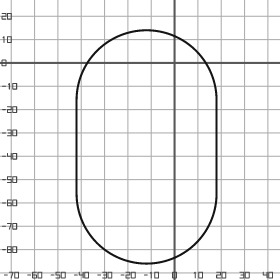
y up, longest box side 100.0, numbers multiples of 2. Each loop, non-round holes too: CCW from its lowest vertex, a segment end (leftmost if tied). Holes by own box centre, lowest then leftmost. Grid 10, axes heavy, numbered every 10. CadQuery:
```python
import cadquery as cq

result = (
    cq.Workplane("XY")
    .moveTo(-42.0, -56.0)
    .threePointArc((-12.0, -86.0), (18.0, -56.0))
    .lineTo(18.0, -16.0)
    .threePointArc((-12.0, 14.0), (-42.0, -16.0))
    .close()
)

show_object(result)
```